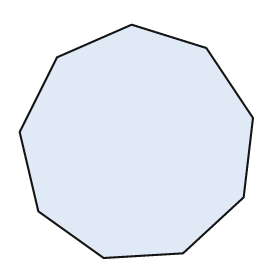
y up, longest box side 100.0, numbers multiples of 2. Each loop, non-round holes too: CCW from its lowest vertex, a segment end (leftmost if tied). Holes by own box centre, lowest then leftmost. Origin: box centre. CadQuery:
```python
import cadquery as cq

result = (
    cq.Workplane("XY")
    .moveTo(-14.0, -50.0)
    .lineTo(20.0, -48.0)
    .lineTo(46.0, -24.0)
    .lineTo(50.0, 10.0)
    .lineTo(30.0, 40.0)
    .lineTo(-2.0, 50.0)
    .lineTo(-34.0, 36.0)
    .lineTo(-50.0, 4.0)
    .lineTo(-42.0, -30.0)
    .close()
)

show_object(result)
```